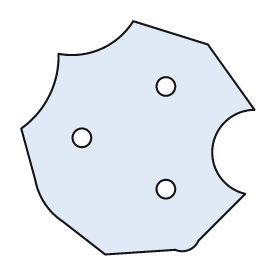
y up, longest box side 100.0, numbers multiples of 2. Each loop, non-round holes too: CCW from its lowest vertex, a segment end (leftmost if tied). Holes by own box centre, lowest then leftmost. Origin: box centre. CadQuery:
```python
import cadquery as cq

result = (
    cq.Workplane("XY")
    .moveTo(-14.0, -50.0)
    .lineTo(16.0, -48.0)
    .threePointArc((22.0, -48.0), (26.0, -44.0))
    .lineTo(46.0, -24.0)
    .threePointArc((32.0, -4.0), (50.0, 12.0))
    .lineTo(30.0, 40.0)
    .lineTo(-2.0, 50.0)
    .threePointArc((-16.0, 38.0), (-34.0, 36.0))
    .threePointArc((-38.0, 18.0), (-50.0, 4.0))
    .lineTo(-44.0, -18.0)
    .threePointArc((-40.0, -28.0), (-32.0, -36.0))
    .close()
    .moveTo(12.0, -22.0)
    .circle(4.0)
    .moveTo(-24.0, 0.0)
    .circle(4.0)
    .moveTo(12.0, 22.0)
    .circle(4.0)
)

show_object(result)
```